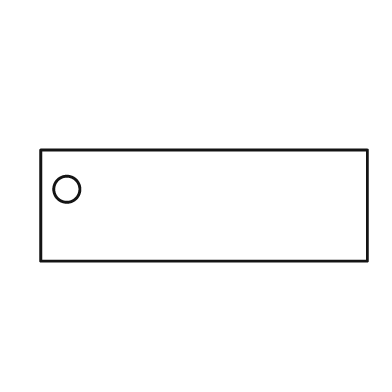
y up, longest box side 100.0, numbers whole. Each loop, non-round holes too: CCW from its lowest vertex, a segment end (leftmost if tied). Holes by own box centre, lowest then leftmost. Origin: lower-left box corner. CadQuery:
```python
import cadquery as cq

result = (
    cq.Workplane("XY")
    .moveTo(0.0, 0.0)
    .lineTo(100.0, 0.0)
    .lineTo(100.0, 34.0)
    .lineTo(0.0, 34.0)
    .close()
    .moveTo(8.0, 22.0)
    .circle(4.0)
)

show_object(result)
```